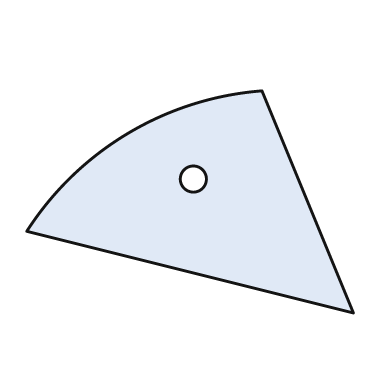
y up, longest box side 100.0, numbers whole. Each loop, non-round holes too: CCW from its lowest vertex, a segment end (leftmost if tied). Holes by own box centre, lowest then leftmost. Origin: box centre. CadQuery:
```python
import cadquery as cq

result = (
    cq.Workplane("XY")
    .moveTo(50.0, -34.0)
    .lineTo(22.0, 34.0)
    .threePointArc((-19.0, 21.0), (-50.0, -9.0))
    .close()
    .moveTo(1.0, 7.0)
    .circle(4.0)
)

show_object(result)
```